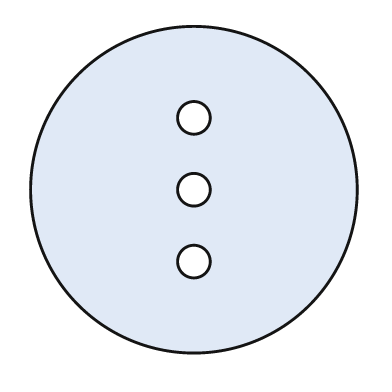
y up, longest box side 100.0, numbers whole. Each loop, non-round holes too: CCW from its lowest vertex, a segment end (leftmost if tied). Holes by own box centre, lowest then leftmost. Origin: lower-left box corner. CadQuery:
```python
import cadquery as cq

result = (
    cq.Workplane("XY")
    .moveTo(50.0, 50.0)
    .circle(50.0)
    .moveTo(50.0, 28.0)
    .circle(5.0)
    .moveTo(50.0, 50.0)
    .circle(5.0)
    .moveTo(50.0, 72.0)
    .circle(5.0)
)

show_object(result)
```